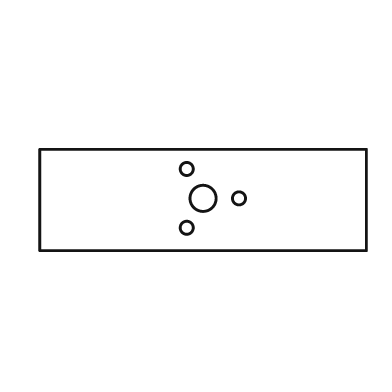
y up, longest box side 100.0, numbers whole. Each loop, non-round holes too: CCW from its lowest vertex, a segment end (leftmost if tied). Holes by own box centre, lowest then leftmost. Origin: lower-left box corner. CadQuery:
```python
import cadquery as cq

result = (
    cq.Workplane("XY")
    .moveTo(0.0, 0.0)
    .lineTo(100.0, 0.0)
    .lineTo(100.0, 31.0)
    .lineTo(0.0, 31.0)
    .close()
    .moveTo(45.0, 7.0)
    .circle(2.0)
    .moveTo(50.0, 16.0)
    .circle(4.0)
    .moveTo(61.0, 16.0)
    .circle(2.0)
    .moveTo(45.0, 25.0)
    .circle(2.0)
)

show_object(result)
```